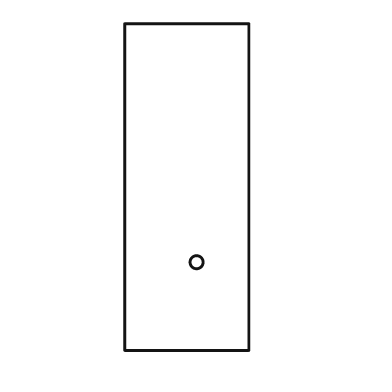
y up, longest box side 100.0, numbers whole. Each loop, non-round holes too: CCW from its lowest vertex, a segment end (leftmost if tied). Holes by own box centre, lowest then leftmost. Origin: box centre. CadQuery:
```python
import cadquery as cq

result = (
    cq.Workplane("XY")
    .moveTo(-19.0, -50.0)
    .lineTo(19.0, -50.0)
    .lineTo(19.0, 50.0)
    .lineTo(-19.0, 50.0)
    .close()
    .moveTo(3.0, -23.0)
    .circle(2.0)
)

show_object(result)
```